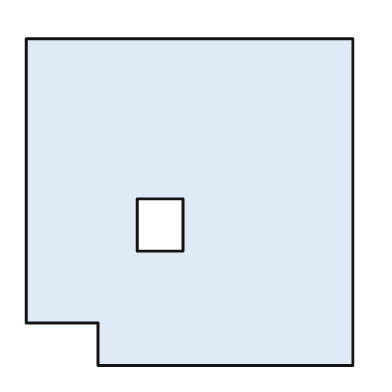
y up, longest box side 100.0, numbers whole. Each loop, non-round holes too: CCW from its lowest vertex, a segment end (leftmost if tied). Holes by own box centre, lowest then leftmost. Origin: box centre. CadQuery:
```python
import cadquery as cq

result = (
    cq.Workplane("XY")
    .moveTo(-28.0, -50.0)
    .lineTo(50.0, -50.0)
    .lineTo(50.0, 50.0)
    .lineTo(-50.0, 50.0)
    .lineTo(-50.0, -37.0)
    .lineTo(-28.0, -37.0)
    .close()
    .moveTo(-16.0, -15.0)
    .lineTo(-2.0, -15.0)
    .lineTo(-2.0, 1.0)
    .lineTo(-16.0, 1.0)
    .close()
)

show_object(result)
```